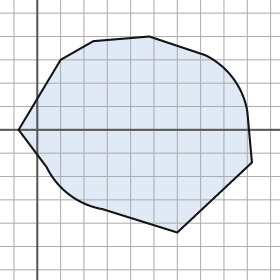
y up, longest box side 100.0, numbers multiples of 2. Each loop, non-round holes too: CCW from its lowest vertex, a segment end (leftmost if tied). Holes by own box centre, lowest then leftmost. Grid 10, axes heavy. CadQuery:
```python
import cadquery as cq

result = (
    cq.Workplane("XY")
    .moveTo(60.0, -44.0)
    .lineTo(92.0, -14.0)
    .lineTo(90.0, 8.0)
    .threePointArc((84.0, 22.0), (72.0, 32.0))
    .lineTo(48.0, 40.0)
    .lineTo(24.0, 38.0)
    .lineTo(10.0, 30.0)
    .lineTo(-8.0, 0.0)
    .lineTo(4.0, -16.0)
    .threePointArc((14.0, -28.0), (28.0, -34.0))
    .close()
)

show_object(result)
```